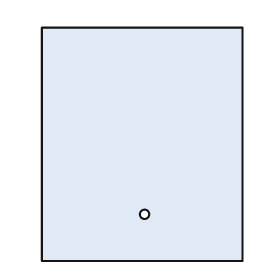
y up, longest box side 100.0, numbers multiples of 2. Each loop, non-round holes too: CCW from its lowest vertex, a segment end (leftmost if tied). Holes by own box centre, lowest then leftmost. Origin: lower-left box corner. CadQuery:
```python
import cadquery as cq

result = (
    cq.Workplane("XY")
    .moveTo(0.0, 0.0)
    .lineTo(86.0, 0.0)
    .lineTo(86.0, 100.0)
    .lineTo(0.0, 100.0)
    .close()
    .moveTo(44.0, 20.0)
    .circle(2.0)
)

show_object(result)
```